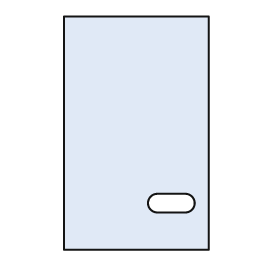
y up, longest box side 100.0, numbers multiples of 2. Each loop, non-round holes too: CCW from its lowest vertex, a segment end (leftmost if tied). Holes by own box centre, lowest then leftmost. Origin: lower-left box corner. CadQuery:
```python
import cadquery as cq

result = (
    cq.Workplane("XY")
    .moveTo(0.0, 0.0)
    .lineTo(62.0, 0.0)
    .lineTo(62.0, 100.0)
    .lineTo(0.0, 100.0)
    .close()
    .moveTo(40.0, 16.0)
    .lineTo(52.0, 16.0)
    .threePointArc((56.0, 20.0), (52.0, 24.0))
    .lineTo(40.0, 24.0)
    .threePointArc((36.0, 20.0), (40.0, 16.0))
    .close()
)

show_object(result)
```